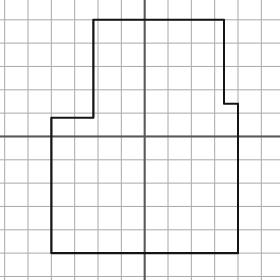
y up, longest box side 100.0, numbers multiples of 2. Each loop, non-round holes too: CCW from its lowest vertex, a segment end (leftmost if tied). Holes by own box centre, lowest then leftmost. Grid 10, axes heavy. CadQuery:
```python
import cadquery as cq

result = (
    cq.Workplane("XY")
    .moveTo(-40.0, -50.0)
    .lineTo(40.0, -50.0)
    .lineTo(40.0, 14.0)
    .lineTo(34.0, 14.0)
    .lineTo(34.0, 50.0)
    .lineTo(-22.0, 50.0)
    .lineTo(-22.0, 8.0)
    .lineTo(-40.0, 8.0)
    .close()
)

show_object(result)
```